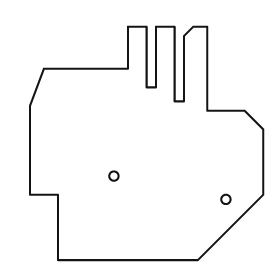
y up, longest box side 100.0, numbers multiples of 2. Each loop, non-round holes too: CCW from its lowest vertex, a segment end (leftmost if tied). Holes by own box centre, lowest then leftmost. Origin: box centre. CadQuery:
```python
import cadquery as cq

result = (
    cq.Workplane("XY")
    .moveTo(-38.0, -50.0)
    .lineTo(22.0, -50.0)
    .lineTo(50.0, -22.0)
    .lineTo(50.0, 6.0)
    .lineTo(42.0, 14.0)
    .lineTo(26.0, 14.0)
    .lineTo(26.0, 50.0)
    .lineTo(20.0, 50.0)
    .lineTo(16.0, 46.0)
    .lineTo(16.0, 18.0)
    .lineTo(12.0, 18.0)
    .lineTo(12.0, 50.0)
    .lineTo(4.0, 50.0)
    .lineTo(4.0, 24.0)
    .lineTo(0.0, 24.0)
    .lineTo(0.0, 50.0)
    .lineTo(-8.0, 50.0)
    .lineTo(-8.0, 32.0)
    .lineTo(-44.0, 32.0)
    .lineTo(-50.0, 16.0)
    .lineTo(-50.0, -22.0)
    .lineTo(-38.0, -22.0)
    .close()
    .moveTo(34.0, -24.0)
    .circle(2.0)
    .moveTo(-14.0, -14.0)
    .circle(2.0)
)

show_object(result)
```